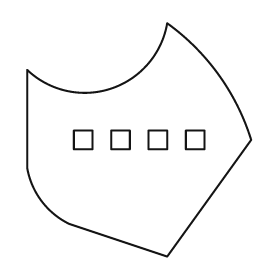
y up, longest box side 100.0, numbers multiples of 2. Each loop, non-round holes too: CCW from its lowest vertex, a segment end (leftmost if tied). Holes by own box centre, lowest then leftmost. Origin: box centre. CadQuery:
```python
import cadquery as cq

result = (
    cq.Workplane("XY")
    .moveTo(12.0, -50.0)
    .lineTo(48.0, 0.0)
    .threePointArc((34.0, 28.0), (12.0, 50.0))
    .threePointArc((-12.0, 22.0), (-48.0, 30.0))
    .lineTo(-48.0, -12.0)
    .threePointArc((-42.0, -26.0), (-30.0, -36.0))
    .close()
    .moveTo(-28.0, -4.0)
    .lineTo(-20.0, -4.0)
    .lineTo(-20.0, 4.0)
    .lineTo(-28.0, 4.0)
    .close()
    .moveTo(-12.0, -4.0)
    .lineTo(-4.0, -4.0)
    .lineTo(-4.0, 4.0)
    .lineTo(-12.0, 4.0)
    .close()
    .moveTo(4.0, -4.0)
    .lineTo(12.0, -4.0)
    .lineTo(12.0, 4.0)
    .lineTo(4.0, 4.0)
    .close()
    .moveTo(20.0, -4.0)
    .lineTo(28.0, -4.0)
    .lineTo(28.0, 4.0)
    .lineTo(20.0, 4.0)
    .close()
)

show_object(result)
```